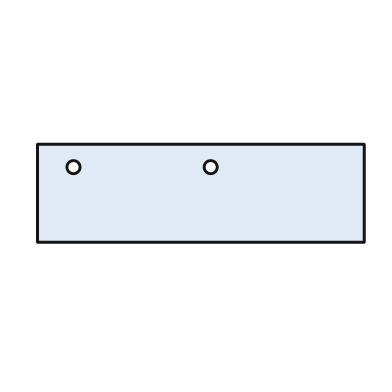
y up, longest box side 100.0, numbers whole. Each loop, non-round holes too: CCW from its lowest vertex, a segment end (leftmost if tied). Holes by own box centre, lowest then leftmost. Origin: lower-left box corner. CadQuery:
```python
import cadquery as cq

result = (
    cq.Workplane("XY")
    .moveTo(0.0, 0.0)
    .lineTo(100.0, 0.0)
    .lineTo(100.0, 30.0)
    .lineTo(0.0, 30.0)
    .close()
    .moveTo(11.0, 23.0)
    .circle(2.0)
    .moveTo(53.0, 23.0)
    .circle(2.0)
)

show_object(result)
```